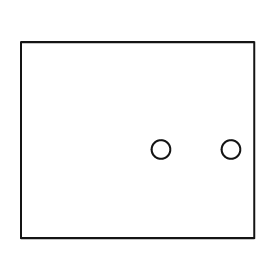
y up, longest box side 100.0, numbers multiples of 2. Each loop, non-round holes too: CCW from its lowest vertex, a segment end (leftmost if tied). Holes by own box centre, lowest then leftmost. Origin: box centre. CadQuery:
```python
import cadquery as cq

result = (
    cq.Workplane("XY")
    .moveTo(-50.0, -42.0)
    .lineTo(50.0, -42.0)
    .lineTo(50.0, 42.0)
    .lineTo(-50.0, 42.0)
    .close()
    .moveTo(10.0, -4.0)
    .circle(4.0)
    .moveTo(40.0, -4.0)
    .circle(4.0)
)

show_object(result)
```